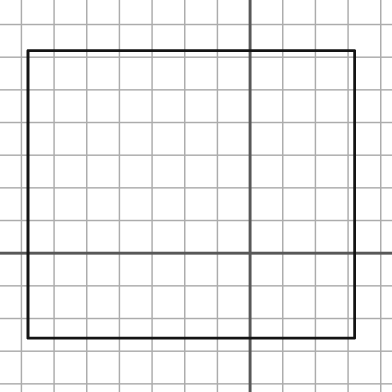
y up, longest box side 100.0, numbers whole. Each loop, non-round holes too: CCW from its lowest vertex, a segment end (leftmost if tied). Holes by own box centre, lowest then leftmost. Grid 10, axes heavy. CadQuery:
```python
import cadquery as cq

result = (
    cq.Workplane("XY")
    .moveTo(-68.0, -26.0)
    .lineTo(32.0, -26.0)
    .lineTo(32.0, 62.0)
    .lineTo(-68.0, 62.0)
    .close()
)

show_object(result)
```